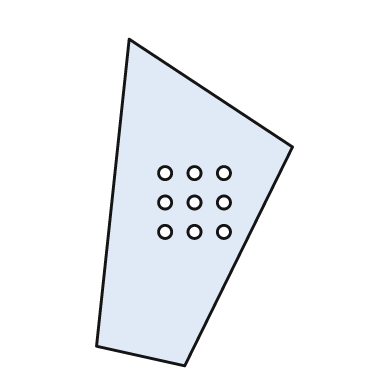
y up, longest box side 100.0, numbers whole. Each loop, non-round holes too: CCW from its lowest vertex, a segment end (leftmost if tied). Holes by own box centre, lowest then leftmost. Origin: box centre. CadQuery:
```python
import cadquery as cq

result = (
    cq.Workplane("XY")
    .moveTo(-3.0, -50.0)
    .lineTo(30.0, 17.0)
    .lineTo(-20.0, 50.0)
    .lineTo(-30.0, -44.0)
    .close()
    .moveTo(-9.0, -9.0)
    .circle(2.0)
    .moveTo(0.0, -9.0)
    .circle(2.0)
    .moveTo(9.0, -9.0)
    .circle(2.0)
    .moveTo(-9.0, 0.0)
    .circle(2.0)
    .moveTo(0.0, 0.0)
    .circle(2.0)
    .moveTo(9.0, 0.0)
    .circle(2.0)
    .moveTo(-9.0, 9.0)
    .circle(2.0)
    .moveTo(0.0, 9.0)
    .circle(2.0)
    .moveTo(9.0, 9.0)
    .circle(2.0)
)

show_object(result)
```